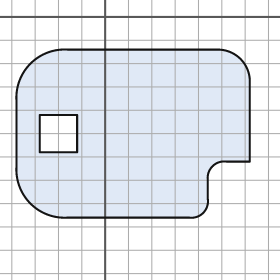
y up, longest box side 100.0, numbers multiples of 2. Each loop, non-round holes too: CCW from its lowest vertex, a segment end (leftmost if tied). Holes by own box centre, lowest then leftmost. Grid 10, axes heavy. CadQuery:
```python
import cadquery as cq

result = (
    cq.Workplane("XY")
    .moveTo(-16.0, -86.0)
    .lineTo(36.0, -86.0)
    .threePointArc((42.0, -84.0), (44.0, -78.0))
    .lineTo(44.0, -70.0)
    .threePointArc((46.0, -64.0), (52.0, -62.0))
    .lineTo(62.0, -62.0)
    .lineTo(62.0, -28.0)
    .threePointArc((58.0, -18.0), (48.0, -14.0))
    .lineTo(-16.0, -14.0)
    .threePointArc((-32.0, -20.0), (-38.0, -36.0))
    .lineTo(-38.0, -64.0)
    .threePointArc((-32.0, -80.0), (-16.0, -86.0))
    .close()
    .moveTo(-28.0, -58.0)
    .lineTo(-12.0, -58.0)
    .lineTo(-12.0, -42.0)
    .lineTo(-28.0, -42.0)
    .close()
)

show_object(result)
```